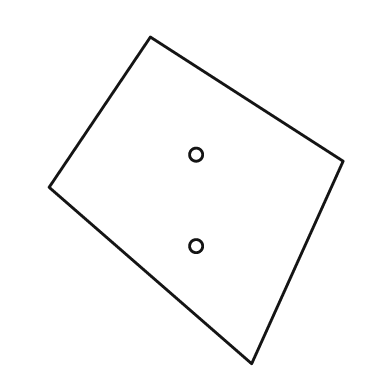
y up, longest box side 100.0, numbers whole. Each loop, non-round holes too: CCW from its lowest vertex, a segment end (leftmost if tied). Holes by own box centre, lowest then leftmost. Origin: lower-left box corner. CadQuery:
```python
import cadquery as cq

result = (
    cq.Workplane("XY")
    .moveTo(62.0, 0.0)
    .lineTo(90.0, 62.0)
    .lineTo(31.0, 100.0)
    .lineTo(0.0, 54.0)
    .close()
    .moveTo(45.0, 36.0)
    .circle(2.0)
    .moveTo(45.0, 64.0)
    .circle(2.0)
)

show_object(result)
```